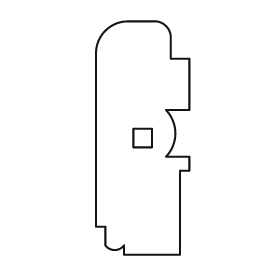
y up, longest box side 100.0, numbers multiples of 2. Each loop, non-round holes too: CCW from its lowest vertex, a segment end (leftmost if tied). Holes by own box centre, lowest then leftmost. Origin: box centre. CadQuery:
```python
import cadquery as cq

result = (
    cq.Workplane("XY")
    .moveTo(-8.0, -50.0)
    .lineTo(16.0, -50.0)
    .lineTo(16.0, -14.0)
    .lineTo(20.0, -14.0)
    .lineTo(20.0, -8.0)
    .lineTo(10.0, -8.0)
    .threePointArc((14.0, 2.0), (10.0, 12.0))
    .lineTo(20.0, 12.0)
    .lineTo(20.0, 34.0)
    .lineTo(12.0, 34.0)
    .lineTo(12.0, 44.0)
    .threePointArc((10.0, 48.0), (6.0, 50.0))
    .lineTo(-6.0, 50.0)
    .threePointArc((-16.0, 46.0), (-20.0, 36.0))
    .lineTo(-20.0, -38.0)
    .lineTo(-16.0, -38.0)
    .lineTo(-16.0, -46.0)
    .threePointArc((-12.0, -48.0), (-8.0, -46.0))
    .close()
    .moveTo(-4.0, -4.0)
    .lineTo(4.0, -4.0)
    .lineTo(4.0, 4.0)
    .lineTo(-4.0, 4.0)
    .close()
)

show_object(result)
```